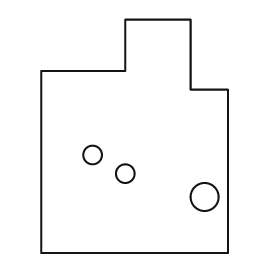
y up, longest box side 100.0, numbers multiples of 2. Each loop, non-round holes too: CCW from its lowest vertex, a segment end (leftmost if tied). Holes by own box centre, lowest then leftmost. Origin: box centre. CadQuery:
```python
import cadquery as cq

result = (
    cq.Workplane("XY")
    .moveTo(-40.0, -50.0)
    .lineTo(40.0, -50.0)
    .lineTo(40.0, 20.0)
    .lineTo(24.0, 20.0)
    .lineTo(24.0, 50.0)
    .lineTo(-4.0, 50.0)
    .lineTo(-4.0, 28.0)
    .lineTo(-40.0, 28.0)
    .close()
    .moveTo(30.0, -26.0)
    .circle(6.0)
    .moveTo(-4.0, -16.0)
    .circle(4.0)
    .moveTo(-18.0, -8.0)
    .circle(4.0)
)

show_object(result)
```